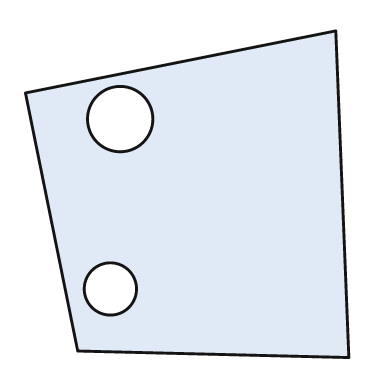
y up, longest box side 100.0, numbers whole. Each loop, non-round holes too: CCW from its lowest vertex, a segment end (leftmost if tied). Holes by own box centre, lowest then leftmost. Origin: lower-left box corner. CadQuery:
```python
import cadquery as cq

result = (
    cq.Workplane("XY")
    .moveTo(99.0, 0.0)
    .lineTo(95.0, 100.0)
    .lineTo(0.0, 81.0)
    .lineTo(16.0, 2.0)
    .close()
    .moveTo(26.0, 21.0)
    .circle(8.0)
    .moveTo(29.0, 73.0)
    .circle(10.0)
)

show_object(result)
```